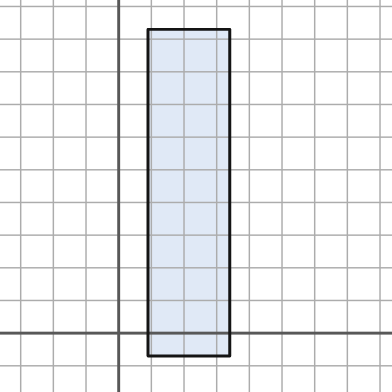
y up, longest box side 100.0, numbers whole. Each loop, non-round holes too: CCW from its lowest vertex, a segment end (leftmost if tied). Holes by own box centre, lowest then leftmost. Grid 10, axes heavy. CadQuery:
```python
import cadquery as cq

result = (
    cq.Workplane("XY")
    .moveTo(9.0, -7.0)
    .lineTo(34.0, -7.0)
    .lineTo(34.0, 93.0)
    .lineTo(9.0, 93.0)
    .close()
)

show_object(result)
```